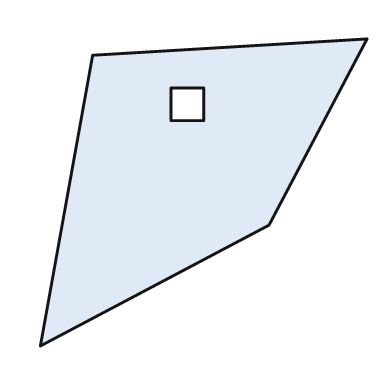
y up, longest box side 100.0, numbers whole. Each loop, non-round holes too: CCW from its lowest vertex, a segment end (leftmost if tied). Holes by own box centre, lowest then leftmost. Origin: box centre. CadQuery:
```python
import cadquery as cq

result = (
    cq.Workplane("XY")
    .moveTo(-50.0, -47.0)
    .lineTo(20.0, -10.0)
    .lineTo(50.0, 47.0)
    .lineTo(-34.0, 42.0)
    .close()
    .moveTo(-10.0, 22.0)
    .lineTo(0.0, 22.0)
    .lineTo(0.0, 32.0)
    .lineTo(-10.0, 32.0)
    .close()
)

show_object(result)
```